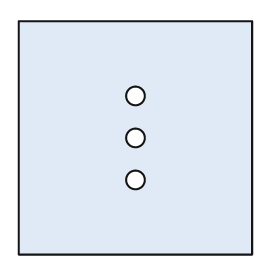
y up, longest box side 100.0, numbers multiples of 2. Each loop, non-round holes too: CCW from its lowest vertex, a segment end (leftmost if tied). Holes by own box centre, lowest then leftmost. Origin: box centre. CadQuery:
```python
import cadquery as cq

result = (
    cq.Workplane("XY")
    .moveTo(-50.0, -50.0)
    .lineTo(50.0, -50.0)
    .lineTo(50.0, 50.0)
    .lineTo(-50.0, 50.0)
    .close()
    .moveTo(0.0, -18.0)
    .circle(4.0)
    .moveTo(0.0, 0.0)
    .circle(4.0)
    .moveTo(0.0, 18.0)
    .circle(4.0)
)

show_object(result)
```